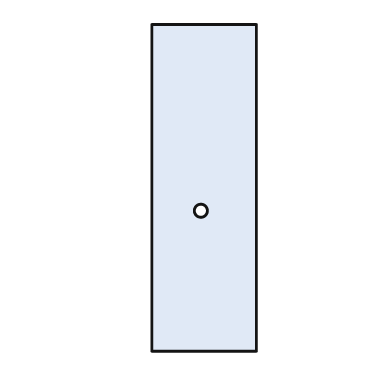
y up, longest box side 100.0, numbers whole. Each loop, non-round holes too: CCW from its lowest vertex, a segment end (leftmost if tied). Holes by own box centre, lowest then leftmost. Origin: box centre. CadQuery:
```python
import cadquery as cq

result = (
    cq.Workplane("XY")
    .moveTo(-16.0, -50.0)
    .lineTo(16.0, -50.0)
    .lineTo(16.0, 50.0)
    .lineTo(-16.0, 50.0)
    .close()
    .moveTo(-1.0, -7.0)
    .circle(2.0)
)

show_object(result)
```